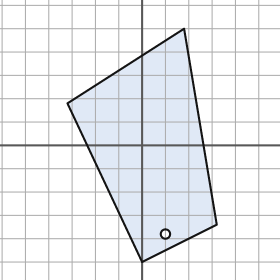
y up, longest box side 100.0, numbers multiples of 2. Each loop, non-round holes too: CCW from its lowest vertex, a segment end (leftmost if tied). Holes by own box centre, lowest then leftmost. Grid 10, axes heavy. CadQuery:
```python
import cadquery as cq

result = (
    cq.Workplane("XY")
    .moveTo(0.0, -50.0)
    .lineTo(32.0, -34.0)
    .lineTo(18.0, 50.0)
    .lineTo(-32.0, 18.0)
    .close()
    .moveTo(10.0, -38.0)
    .circle(2.0)
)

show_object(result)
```